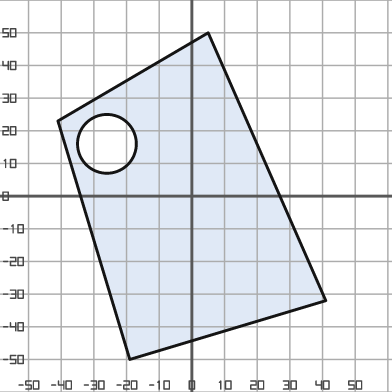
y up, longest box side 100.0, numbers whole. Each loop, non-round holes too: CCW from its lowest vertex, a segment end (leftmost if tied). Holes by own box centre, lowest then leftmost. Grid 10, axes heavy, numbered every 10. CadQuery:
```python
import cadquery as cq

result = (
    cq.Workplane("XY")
    .moveTo(-19.0, -50.0)
    .lineTo(41.0, -32.0)
    .lineTo(5.0, 50.0)
    .lineTo(-41.0, 23.0)
    .close()
    .moveTo(-26.0, 16.0)
    .circle(9.0)
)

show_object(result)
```